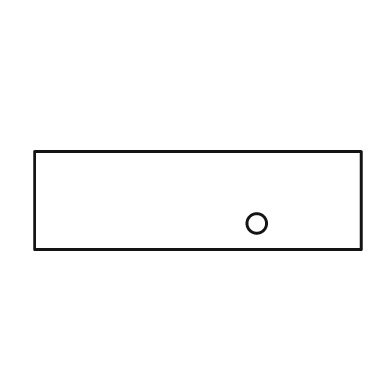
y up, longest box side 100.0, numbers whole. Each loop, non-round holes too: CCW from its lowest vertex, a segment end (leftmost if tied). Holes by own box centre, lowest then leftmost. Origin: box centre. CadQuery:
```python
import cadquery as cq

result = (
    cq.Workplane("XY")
    .moveTo(-50.0, -15.0)
    .lineTo(50.0, -15.0)
    .lineTo(50.0, 15.0)
    .lineTo(-50.0, 15.0)
    .close()
    .moveTo(18.0, -7.0)
    .circle(3.0)
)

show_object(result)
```